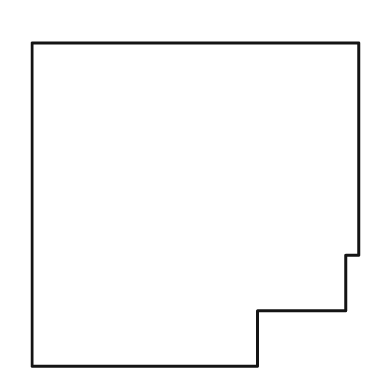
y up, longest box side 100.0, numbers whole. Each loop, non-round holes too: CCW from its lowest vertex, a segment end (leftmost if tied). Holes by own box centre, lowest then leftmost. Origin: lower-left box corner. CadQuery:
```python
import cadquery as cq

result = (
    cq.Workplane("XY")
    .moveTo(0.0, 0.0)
    .lineTo(69.0, 0.0)
    .lineTo(69.0, 17.0)
    .lineTo(96.0, 17.0)
    .lineTo(96.0, 34.0)
    .lineTo(100.0, 34.0)
    .lineTo(100.0, 99.0)
    .lineTo(0.0, 99.0)
    .close()
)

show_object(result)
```